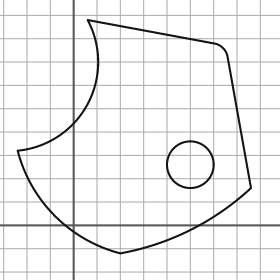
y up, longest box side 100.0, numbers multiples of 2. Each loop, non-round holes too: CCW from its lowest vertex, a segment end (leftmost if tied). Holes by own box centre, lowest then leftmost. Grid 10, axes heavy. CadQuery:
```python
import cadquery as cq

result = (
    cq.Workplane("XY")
    .moveTo(20.0, -12.0)
    .threePointArc((50.0, -2.0), (76.0, 16.0))
    .lineTo(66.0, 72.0)
    .threePointArc((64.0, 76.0), (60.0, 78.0))
    .lineTo(6.0, 88.0)
    .threePointArc((6.0, 52.0), (-24.0, 32.0))
    .threePointArc((-8.0, 4.0), (20.0, -12.0))
    .close()
    .moveTo(50.0, 26.0)
    .circle(10.0)
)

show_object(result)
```